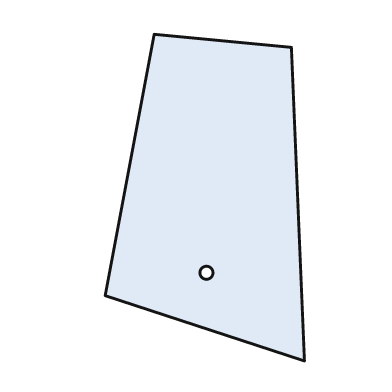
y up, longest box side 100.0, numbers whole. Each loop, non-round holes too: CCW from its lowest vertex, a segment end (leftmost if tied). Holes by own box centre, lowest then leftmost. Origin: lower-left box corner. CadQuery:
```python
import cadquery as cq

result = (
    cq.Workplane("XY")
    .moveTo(61.0, 0.0)
    .lineTo(57.0, 96.0)
    .lineTo(15.0, 100.0)
    .lineTo(0.0, 20.0)
    .close()
    .moveTo(31.0, 27.0)
    .circle(2.0)
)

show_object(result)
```